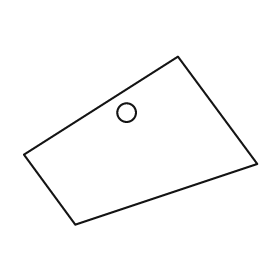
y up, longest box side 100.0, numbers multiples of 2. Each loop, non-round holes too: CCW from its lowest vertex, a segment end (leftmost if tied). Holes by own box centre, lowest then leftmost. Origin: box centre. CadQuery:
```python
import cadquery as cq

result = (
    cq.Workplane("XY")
    .moveTo(-28.0, -36.0)
    .lineTo(50.0, -10.0)
    .lineTo(16.0, 36.0)
    .lineTo(-50.0, -6.0)
    .close()
    .moveTo(-6.0, 12.0)
    .circle(4.0)
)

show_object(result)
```